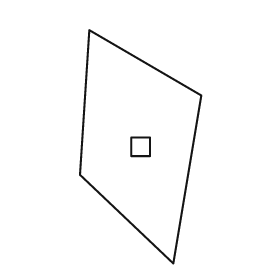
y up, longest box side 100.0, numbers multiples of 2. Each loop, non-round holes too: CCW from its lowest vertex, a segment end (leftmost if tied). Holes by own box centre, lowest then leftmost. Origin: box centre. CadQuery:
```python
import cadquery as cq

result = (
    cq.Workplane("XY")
    .moveTo(14.0, -50.0)
    .lineTo(26.0, 22.0)
    .lineTo(-22.0, 50.0)
    .lineTo(-26.0, -12.0)
    .close()
    .moveTo(-4.0, -4.0)
    .lineTo(4.0, -4.0)
    .lineTo(4.0, 4.0)
    .lineTo(-4.0, 4.0)
    .close()
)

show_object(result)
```